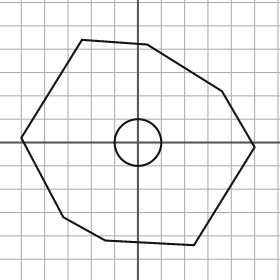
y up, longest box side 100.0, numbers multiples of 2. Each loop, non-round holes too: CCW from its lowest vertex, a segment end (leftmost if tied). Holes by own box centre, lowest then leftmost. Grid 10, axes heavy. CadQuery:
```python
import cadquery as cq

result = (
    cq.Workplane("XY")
    .moveTo(24.0, -44.0)
    .lineTo(50.0, -2.0)
    .lineTo(36.0, 22.0)
    .lineTo(4.0, 42.0)
    .lineTo(-24.0, 44.0)
    .lineTo(-50.0, 2.0)
    .lineTo(-32.0, -32.0)
    .lineTo(-14.0, -42.0)
    .close()
    .moveTo(0.0, 0.0)
    .circle(10.0)
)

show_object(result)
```